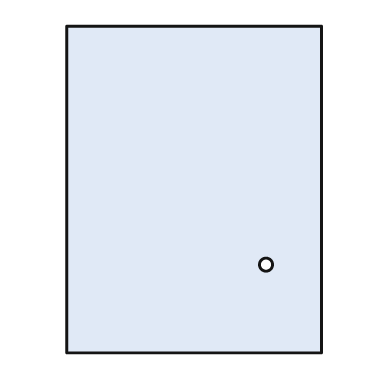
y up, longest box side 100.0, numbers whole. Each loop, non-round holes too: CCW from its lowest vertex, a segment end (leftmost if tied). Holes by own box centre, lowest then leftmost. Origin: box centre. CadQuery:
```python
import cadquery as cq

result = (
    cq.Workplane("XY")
    .moveTo(-39.0, -50.0)
    .lineTo(39.0, -50.0)
    .lineTo(39.0, 50.0)
    .lineTo(-39.0, 50.0)
    .close()
    .moveTo(22.0, -23.0)
    .circle(2.0)
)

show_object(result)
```